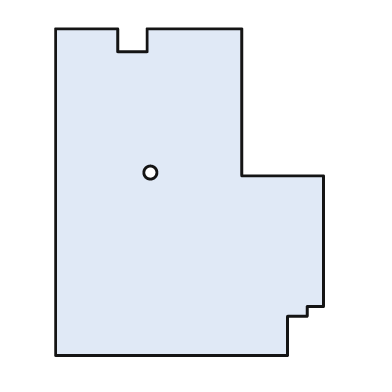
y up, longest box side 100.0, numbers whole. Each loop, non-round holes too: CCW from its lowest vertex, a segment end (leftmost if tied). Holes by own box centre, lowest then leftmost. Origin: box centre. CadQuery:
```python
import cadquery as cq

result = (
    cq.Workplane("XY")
    .moveTo(-41.0, -50.0)
    .lineTo(30.0, -50.0)
    .lineTo(30.0, -38.0)
    .lineTo(36.0, -38.0)
    .lineTo(36.0, -35.0)
    .lineTo(41.0, -35.0)
    .lineTo(41.0, 5.0)
    .lineTo(16.0, 5.0)
    .lineTo(16.0, 50.0)
    .lineTo(-13.0, 50.0)
    .lineTo(-13.0, 43.0)
    .lineTo(-22.0, 43.0)
    .lineTo(-22.0, 50.0)
    .lineTo(-41.0, 50.0)
    .close()
    .moveTo(-12.0, 6.0)
    .circle(2.0)
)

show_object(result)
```